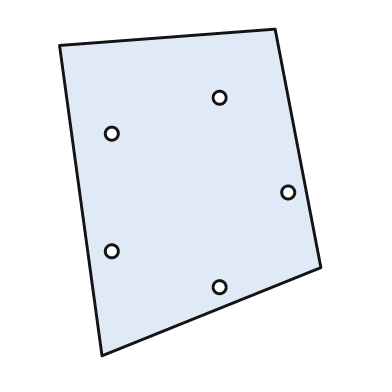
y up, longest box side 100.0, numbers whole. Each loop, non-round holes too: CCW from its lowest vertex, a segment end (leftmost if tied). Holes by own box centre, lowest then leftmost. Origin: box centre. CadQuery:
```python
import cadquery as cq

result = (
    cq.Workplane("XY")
    .moveTo(-27.0, -50.0)
    .lineTo(40.0, -23.0)
    .lineTo(26.0, 50.0)
    .lineTo(-40.0, 45.0)
    .close()
    .moveTo(9.0, -29.0)
    .circle(2.0)
    .moveTo(-24.0, -18.0)
    .circle(2.0)
    .moveTo(30.0, 0.0)
    .circle(2.0)
    .moveTo(-24.0, 18.0)
    .circle(2.0)
    .moveTo(9.0, 29.0)
    .circle(2.0)
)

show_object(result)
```